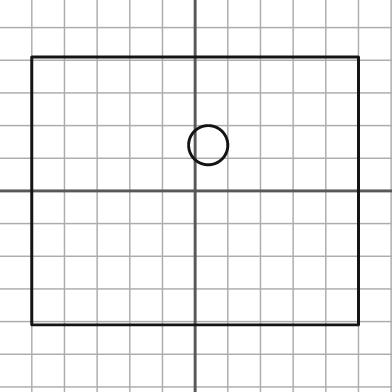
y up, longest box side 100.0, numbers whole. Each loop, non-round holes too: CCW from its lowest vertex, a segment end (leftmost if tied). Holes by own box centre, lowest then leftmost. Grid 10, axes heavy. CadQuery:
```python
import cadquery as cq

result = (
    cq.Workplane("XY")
    .moveTo(-50.0, -41.0)
    .lineTo(50.0, -41.0)
    .lineTo(50.0, 41.0)
    .lineTo(-50.0, 41.0)
    .close()
    .moveTo(4.0, 14.0)
    .circle(6.0)
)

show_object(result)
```